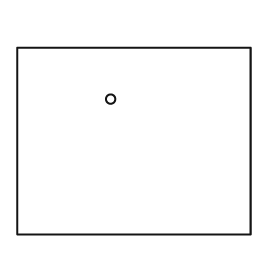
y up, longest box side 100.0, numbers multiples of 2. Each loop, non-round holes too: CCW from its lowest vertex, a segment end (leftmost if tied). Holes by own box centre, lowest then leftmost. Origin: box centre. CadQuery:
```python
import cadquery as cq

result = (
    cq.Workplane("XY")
    .moveTo(-50.0, -40.0)
    .lineTo(50.0, -40.0)
    .lineTo(50.0, 40.0)
    .lineTo(-50.0, 40.0)
    .close()
    .moveTo(-10.0, 18.0)
    .circle(2.0)
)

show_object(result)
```